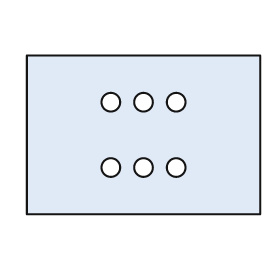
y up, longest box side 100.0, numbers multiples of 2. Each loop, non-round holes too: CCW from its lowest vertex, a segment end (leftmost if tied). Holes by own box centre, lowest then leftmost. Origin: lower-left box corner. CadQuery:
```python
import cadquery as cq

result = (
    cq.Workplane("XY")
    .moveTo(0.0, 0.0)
    .lineTo(100.0, 0.0)
    .lineTo(100.0, 68.0)
    .lineTo(0.0, 68.0)
    .close()
    .moveTo(36.0, 20.0)
    .circle(4.0)
    .moveTo(50.0, 20.0)
    .circle(4.0)
    .moveTo(64.0, 20.0)
    .circle(4.0)
    .moveTo(36.0, 48.0)
    .circle(4.0)
    .moveTo(50.0, 48.0)
    .circle(4.0)
    .moveTo(64.0, 48.0)
    .circle(4.0)
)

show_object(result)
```